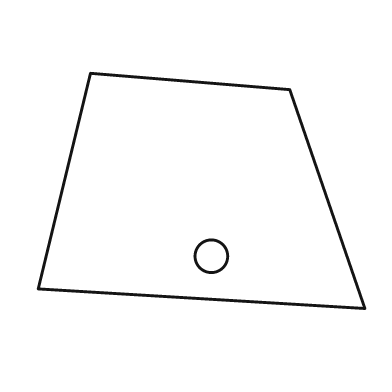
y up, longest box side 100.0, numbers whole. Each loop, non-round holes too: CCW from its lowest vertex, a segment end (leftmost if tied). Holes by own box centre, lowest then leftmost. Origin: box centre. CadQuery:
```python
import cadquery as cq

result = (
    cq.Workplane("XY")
    .moveTo(50.0, -36.0)
    .lineTo(27.0, 31.0)
    .lineTo(-34.0, 36.0)
    .lineTo(-50.0, -30.0)
    .close()
    .moveTo(3.0, -20.0)
    .circle(5.0)
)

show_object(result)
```